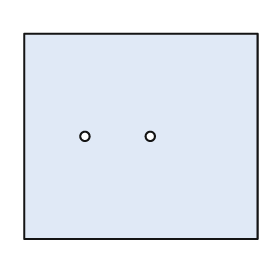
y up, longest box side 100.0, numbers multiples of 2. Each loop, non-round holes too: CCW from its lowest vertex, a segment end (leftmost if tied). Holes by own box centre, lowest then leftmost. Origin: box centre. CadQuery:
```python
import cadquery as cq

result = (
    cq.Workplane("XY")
    .moveTo(-50.0, -44.0)
    .lineTo(50.0, -44.0)
    .lineTo(50.0, 44.0)
    .lineTo(-50.0, 44.0)
    .close()
    .moveTo(-24.0, 0.0)
    .circle(2.0)
    .moveTo(4.0, 0.0)
    .circle(2.0)
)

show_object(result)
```